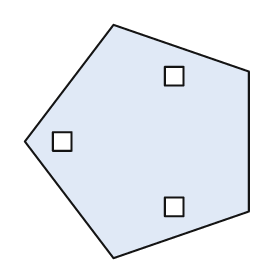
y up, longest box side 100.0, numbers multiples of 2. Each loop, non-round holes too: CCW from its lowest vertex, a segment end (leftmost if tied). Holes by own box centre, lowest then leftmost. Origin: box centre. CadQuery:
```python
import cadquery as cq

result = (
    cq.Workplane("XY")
    .moveTo(-10.0, -50.0)
    .lineTo(48.0, -30.0)
    .lineTo(48.0, 30.0)
    .lineTo(-10.0, 50.0)
    .lineTo(-48.0, 0.0)
    .close()
    .moveTo(12.0, -32.0)
    .lineTo(20.0, -32.0)
    .lineTo(20.0, -24.0)
    .lineTo(12.0, -24.0)
    .close()
    .moveTo(-36.0, -4.0)
    .lineTo(-28.0, -4.0)
    .lineTo(-28.0, 4.0)
    .lineTo(-36.0, 4.0)
    .close()
    .moveTo(12.0, 24.0)
    .lineTo(20.0, 24.0)
    .lineTo(20.0, 32.0)
    .lineTo(12.0, 32.0)
    .close()
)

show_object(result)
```